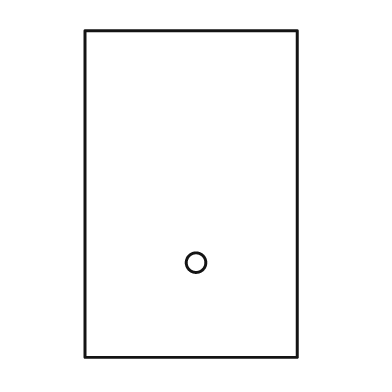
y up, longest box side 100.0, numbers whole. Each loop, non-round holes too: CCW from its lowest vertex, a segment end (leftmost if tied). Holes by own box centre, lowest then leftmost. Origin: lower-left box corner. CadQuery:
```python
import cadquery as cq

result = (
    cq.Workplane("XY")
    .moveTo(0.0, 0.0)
    .lineTo(65.0, 0.0)
    .lineTo(65.0, 100.0)
    .lineTo(0.0, 100.0)
    .close()
    .moveTo(34.0, 29.0)
    .circle(3.0)
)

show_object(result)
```